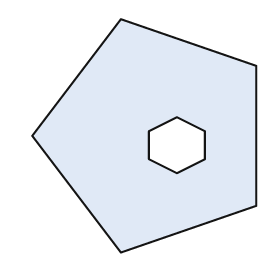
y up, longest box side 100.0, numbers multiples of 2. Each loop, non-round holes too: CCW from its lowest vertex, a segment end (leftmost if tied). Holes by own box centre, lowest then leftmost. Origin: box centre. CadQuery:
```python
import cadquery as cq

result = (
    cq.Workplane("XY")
    .moveTo(-10.0, -50.0)
    .lineTo(48.0, -30.0)
    .lineTo(48.0, 30.0)
    .lineTo(-10.0, 50.0)
    .lineTo(-48.0, 0.0)
    .close()
    .moveTo(14.0, -16.0)
    .lineTo(26.0, -10.0)
    .lineTo(26.0, 2.0)
    .lineTo(14.0, 8.0)
    .lineTo(2.0, 2.0)
    .lineTo(2.0, -10.0)
    .close()
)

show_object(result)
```